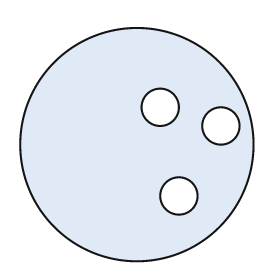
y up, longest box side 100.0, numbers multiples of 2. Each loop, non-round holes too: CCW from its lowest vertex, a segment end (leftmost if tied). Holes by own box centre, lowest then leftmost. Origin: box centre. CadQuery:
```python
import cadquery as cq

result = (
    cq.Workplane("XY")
    .moveTo(0.0, 0.0)
    .circle(50.0)
    .moveTo(18.0, -22.0)
    .circle(8.0)
    .moveTo(36.0, 8.0)
    .circle(8.0)
    .moveTo(10.0, 16.0)
    .circle(8.0)
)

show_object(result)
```